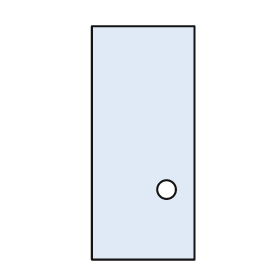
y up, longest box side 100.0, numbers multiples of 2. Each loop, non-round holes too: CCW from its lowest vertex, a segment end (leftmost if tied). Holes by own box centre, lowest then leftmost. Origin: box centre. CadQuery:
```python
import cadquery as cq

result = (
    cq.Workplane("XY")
    .moveTo(-22.0, -50.0)
    .lineTo(22.0, -50.0)
    .lineTo(22.0, 50.0)
    .lineTo(-22.0, 50.0)
    .close()
    .moveTo(10.0, -20.0)
    .circle(4.0)
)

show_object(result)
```